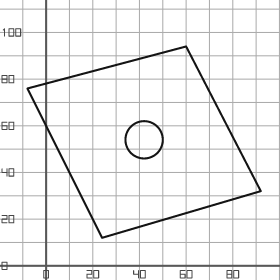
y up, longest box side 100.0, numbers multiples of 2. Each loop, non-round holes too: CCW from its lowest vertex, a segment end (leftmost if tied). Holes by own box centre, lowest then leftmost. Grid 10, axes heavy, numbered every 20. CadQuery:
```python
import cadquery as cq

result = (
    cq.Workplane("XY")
    .moveTo(24.0, 12.0)
    .lineTo(92.0, 32.0)
    .lineTo(60.0, 94.0)
    .lineTo(-8.0, 76.0)
    .close()
    .moveTo(42.0, 54.0)
    .circle(8.0)
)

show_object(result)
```